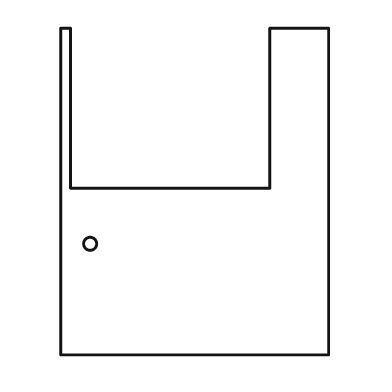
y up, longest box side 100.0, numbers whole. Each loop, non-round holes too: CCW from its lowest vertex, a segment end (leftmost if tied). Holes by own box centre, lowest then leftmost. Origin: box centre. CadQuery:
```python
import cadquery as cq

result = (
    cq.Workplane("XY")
    .moveTo(-41.0, -50.0)
    .lineTo(41.0, -50.0)
    .lineTo(41.0, 50.0)
    .lineTo(23.0, 50.0)
    .lineTo(23.0, 1.0)
    .lineTo(-38.0, 1.0)
    .lineTo(-38.0, 50.0)
    .lineTo(-41.0, 50.0)
    .close()
    .moveTo(-32.0, -16.0)
    .circle(2.0)
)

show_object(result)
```